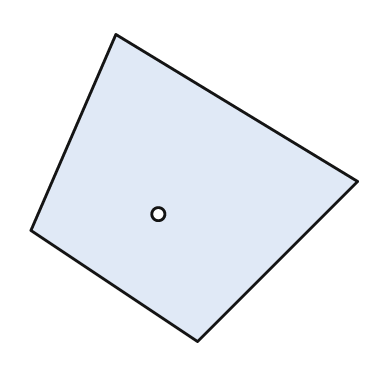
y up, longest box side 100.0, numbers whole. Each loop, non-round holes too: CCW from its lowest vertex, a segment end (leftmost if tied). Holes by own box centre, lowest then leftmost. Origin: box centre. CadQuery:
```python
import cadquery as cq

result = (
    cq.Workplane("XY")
    .moveTo(1.0, -47.0)
    .lineTo(50.0, 2.0)
    .lineTo(-24.0, 47.0)
    .lineTo(-50.0, -13.0)
    .close()
    .moveTo(-11.0, -8.0)
    .circle(2.0)
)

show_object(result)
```